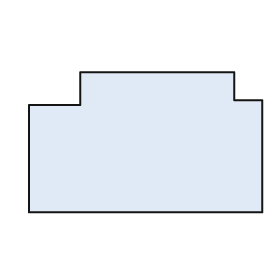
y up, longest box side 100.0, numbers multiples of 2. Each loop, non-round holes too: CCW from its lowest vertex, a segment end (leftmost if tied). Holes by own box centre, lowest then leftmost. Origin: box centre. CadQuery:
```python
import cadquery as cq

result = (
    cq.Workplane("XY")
    .moveTo(-50.0, -30.0)
    .lineTo(50.0, -30.0)
    .lineTo(50.0, 18.0)
    .lineTo(38.0, 18.0)
    .lineTo(38.0, 30.0)
    .lineTo(-28.0, 30.0)
    .lineTo(-28.0, 16.0)
    .lineTo(-50.0, 16.0)
    .close()
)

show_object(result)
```